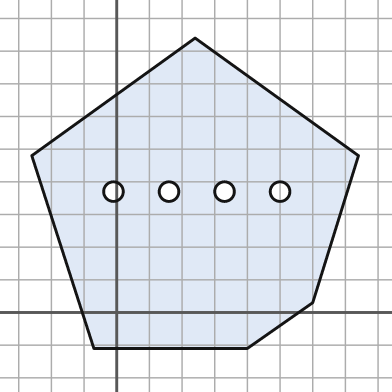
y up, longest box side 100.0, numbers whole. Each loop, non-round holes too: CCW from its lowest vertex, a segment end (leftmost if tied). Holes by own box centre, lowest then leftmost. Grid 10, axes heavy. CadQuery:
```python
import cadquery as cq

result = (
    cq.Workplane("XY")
    .moveTo(-7.0, -11.0)
    .lineTo(40.0, -11.0)
    .lineTo(60.0, 3.0)
    .lineTo(74.0, 48.0)
    .lineTo(24.0, 84.0)
    .lineTo(-26.0, 48.0)
    .close()
    .moveTo(-1.0, 37.0)
    .circle(3.0)
    .moveTo(16.0, 37.0)
    .circle(3.0)
    .moveTo(33.0, 37.0)
    .circle(3.0)
    .moveTo(50.0, 37.0)
    .circle(3.0)
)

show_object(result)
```